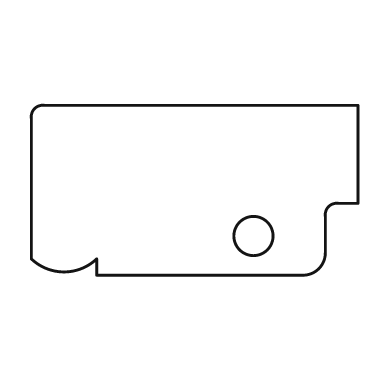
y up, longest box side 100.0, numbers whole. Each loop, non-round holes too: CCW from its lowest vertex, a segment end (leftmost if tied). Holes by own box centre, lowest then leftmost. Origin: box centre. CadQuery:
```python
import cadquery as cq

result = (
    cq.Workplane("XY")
    .moveTo(-30.0, -26.0)
    .lineTo(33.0, -26.0)
    .threePointArc((38.0, -24.0), (40.0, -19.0))
    .lineTo(40.0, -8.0)
    .threePointArc((41.0, -5.0), (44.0, -4.0))
    .lineTo(50.0, -4.0)
    .lineTo(50.0, 26.0)
    .lineTo(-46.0, 26.0)
    .threePointArc((-49.0, 25.0), (-50.0, 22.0))
    .lineTo(-50.0, -21.0)
    .threePointArc((-40.0, -25.0), (-30.0, -21.0))
    .close()
    .moveTo(18.0, -14.0)
    .circle(6.0)
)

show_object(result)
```